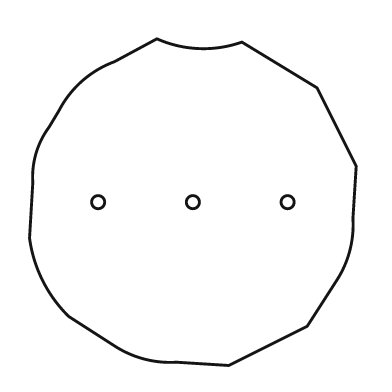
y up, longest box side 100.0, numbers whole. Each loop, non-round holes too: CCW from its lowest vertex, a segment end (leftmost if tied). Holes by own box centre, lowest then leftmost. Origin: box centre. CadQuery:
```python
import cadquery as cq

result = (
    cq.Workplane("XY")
    .moveTo(11.0, -50.0)
    .lineTo(35.0, -38.0)
    .lineTo(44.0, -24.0)
    .threePointArc((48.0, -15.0), (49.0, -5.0))
    .lineTo(50.0, 11.0)
    .lineTo(38.0, 35.0)
    .lineTo(15.0, 49.0)
    .threePointArc((2.0, 47.0), (-11.0, 50.0))
    .lineTo(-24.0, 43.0)
    .threePointArc((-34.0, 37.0), (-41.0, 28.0))
    .lineTo(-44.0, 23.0)
    .threePointArc((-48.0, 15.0), (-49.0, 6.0))
    .lineTo(-50.0, -11.0)
    .threePointArc((-46.0, -24.0), (-38.0, -35.0))
    .lineTo(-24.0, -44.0)
    .threePointArc((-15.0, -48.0), (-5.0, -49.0))
    .close()
    .moveTo(-29.0, 0.0)
    .circle(2.0)
    .moveTo(0.0, 0.0)
    .circle(2.0)
    .moveTo(29.0, 0.0)
    .circle(2.0)
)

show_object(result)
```